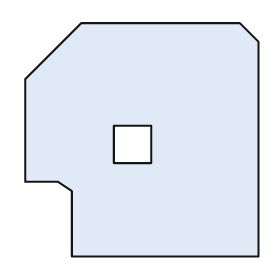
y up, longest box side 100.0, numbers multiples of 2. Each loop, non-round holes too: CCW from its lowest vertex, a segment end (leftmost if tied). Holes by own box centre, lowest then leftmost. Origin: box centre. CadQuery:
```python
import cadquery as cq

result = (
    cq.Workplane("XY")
    .moveTo(-30.0, -50.0)
    .lineTo(50.0, -50.0)
    .lineTo(50.0, 42.0)
    .lineTo(42.0, 50.0)
    .lineTo(-26.0, 50.0)
    .lineTo(-50.0, 26.0)
    .lineTo(-50.0, -18.0)
    .lineTo(-36.0, -18.0)
    .lineTo(-30.0, -22.0)
    .close()
    .moveTo(-12.0, -10.0)
    .lineTo(4.0, -10.0)
    .lineTo(4.0, 6.0)
    .lineTo(-12.0, 6.0)
    .close()
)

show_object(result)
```